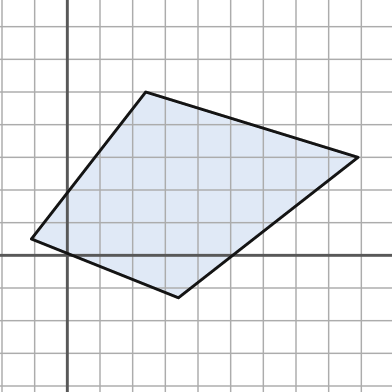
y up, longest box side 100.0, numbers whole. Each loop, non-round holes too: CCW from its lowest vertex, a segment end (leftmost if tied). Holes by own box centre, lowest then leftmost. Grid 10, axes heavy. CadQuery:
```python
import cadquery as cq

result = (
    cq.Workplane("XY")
    .moveTo(34.0, -13.0)
    .lineTo(89.0, 30.0)
    .lineTo(24.0, 50.0)
    .lineTo(-11.0, 5.0)
    .close()
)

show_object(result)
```